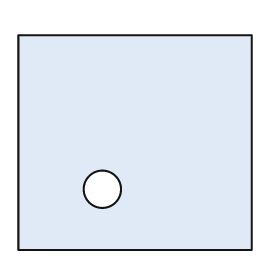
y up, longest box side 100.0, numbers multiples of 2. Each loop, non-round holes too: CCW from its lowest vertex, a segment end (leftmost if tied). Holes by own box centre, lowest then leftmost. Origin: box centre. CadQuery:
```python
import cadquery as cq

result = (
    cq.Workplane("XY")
    .moveTo(-50.0, -46.0)
    .lineTo(50.0, -46.0)
    .lineTo(50.0, 46.0)
    .lineTo(-50.0, 46.0)
    .close()
    .moveTo(-14.0, -20.0)
    .circle(8.0)
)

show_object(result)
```